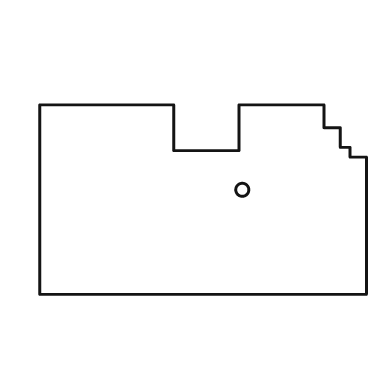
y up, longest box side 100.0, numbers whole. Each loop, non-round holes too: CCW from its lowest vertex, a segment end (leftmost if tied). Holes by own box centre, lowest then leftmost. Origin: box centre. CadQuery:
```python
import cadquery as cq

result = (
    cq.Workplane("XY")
    .moveTo(-50.0, -29.0)
    .lineTo(50.0, -29.0)
    .lineTo(50.0, 13.0)
    .lineTo(45.0, 13.0)
    .lineTo(45.0, 16.0)
    .lineTo(42.0, 16.0)
    .lineTo(42.0, 22.0)
    .lineTo(37.0, 22.0)
    .lineTo(37.0, 29.0)
    .lineTo(11.0, 29.0)
    .lineTo(11.0, 15.0)
    .lineTo(-9.0, 15.0)
    .lineTo(-9.0, 29.0)
    .lineTo(-50.0, 29.0)
    .close()
    .moveTo(12.0, 3.0)
    .circle(2.0)
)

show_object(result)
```